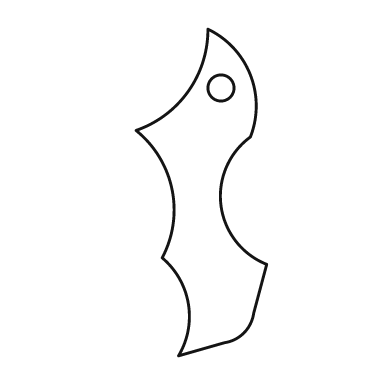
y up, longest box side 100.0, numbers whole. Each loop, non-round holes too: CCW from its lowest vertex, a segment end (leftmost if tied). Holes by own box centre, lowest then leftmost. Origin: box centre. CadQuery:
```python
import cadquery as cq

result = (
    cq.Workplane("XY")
    .moveTo(-7.0, -50.0)
    .lineTo(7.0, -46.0)
    .threePointArc((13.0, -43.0), (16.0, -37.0))
    .lineTo(20.0, -22.0)
    .threePointArc((6.0, -4.0), (15.0, 17.0))
    .threePointArc((15.0, 36.0), (2.0, 50.0))
    .threePointArc((-4.0, 31.0), (-20.0, 19.0))
    .threePointArc((-9.0, 1.0), (-12.0, -20.0))
    .threePointArc((-4.0, -34.0), (-7.0, -50.0))
    .close()
    .moveTo(6.0, 32.0)
    .circle(4.0)
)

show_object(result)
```